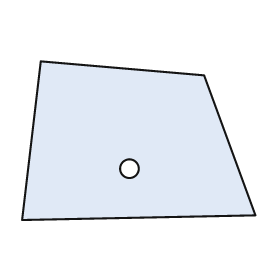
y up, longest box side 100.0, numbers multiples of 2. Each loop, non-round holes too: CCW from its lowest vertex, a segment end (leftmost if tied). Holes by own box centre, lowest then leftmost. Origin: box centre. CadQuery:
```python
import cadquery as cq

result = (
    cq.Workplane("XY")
    .moveTo(-50.0, -34.0)
    .lineTo(50.0, -32.0)
    .lineTo(28.0, 28.0)
    .lineTo(-42.0, 34.0)
    .close()
    .moveTo(-4.0, -12.0)
    .circle(4.0)
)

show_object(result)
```